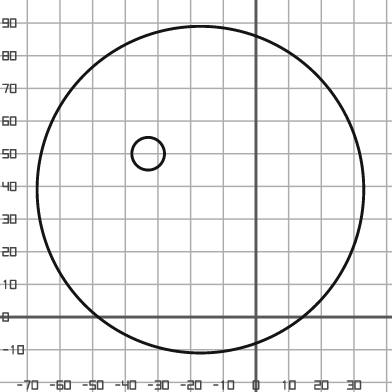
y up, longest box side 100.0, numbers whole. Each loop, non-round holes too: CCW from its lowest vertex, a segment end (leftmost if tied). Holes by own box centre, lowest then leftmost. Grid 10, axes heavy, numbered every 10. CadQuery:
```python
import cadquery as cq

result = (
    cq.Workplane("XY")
    .moveTo(-17.0, 39.0)
    .circle(50.0)
    .moveTo(-33.0, 50.0)
    .circle(5.0)
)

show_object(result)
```